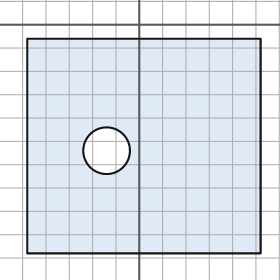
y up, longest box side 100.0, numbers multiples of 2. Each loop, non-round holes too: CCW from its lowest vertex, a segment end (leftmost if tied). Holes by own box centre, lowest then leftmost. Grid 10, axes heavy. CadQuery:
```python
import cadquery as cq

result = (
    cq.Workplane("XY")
    .moveTo(-48.0, -98.0)
    .lineTo(52.0, -98.0)
    .lineTo(52.0, -6.0)
    .lineTo(-48.0, -6.0)
    .close()
    .moveTo(-14.0, -54.0)
    .circle(10.0)
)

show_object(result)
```